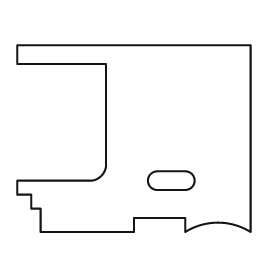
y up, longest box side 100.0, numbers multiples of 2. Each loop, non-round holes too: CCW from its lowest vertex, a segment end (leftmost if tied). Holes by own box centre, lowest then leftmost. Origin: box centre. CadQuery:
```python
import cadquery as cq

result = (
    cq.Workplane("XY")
    .moveTo(-40.0, -40.0)
    .lineTo(0.0, -40.0)
    .lineTo(0.0, -34.0)
    .lineTo(22.0, -34.0)
    .lineTo(22.0, -40.0)
    .threePointArc((36.0, -36.0), (50.0, -40.0))
    .lineTo(50.0, 40.0)
    .lineTo(-50.0, 40.0)
    .lineTo(-50.0, 32.0)
    .lineTo(-12.0, 32.0)
    .lineTo(-12.0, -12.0)
    .threePointArc((-14.0, -16.0), (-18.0, -18.0))
    .lineTo(-50.0, -18.0)
    .lineTo(-50.0, -24.0)
    .lineTo(-44.0, -24.0)
    .lineTo(-44.0, -30.0)
    .lineTo(-40.0, -30.0)
    .close()
    .moveTo(10.0, -22.0)
    .lineTo(22.0, -22.0)
    .threePointArc((26.0, -18.0), (22.0, -14.0))
    .lineTo(10.0, -14.0)
    .threePointArc((6.0, -18.0), (10.0, -22.0))
    .close()
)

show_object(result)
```